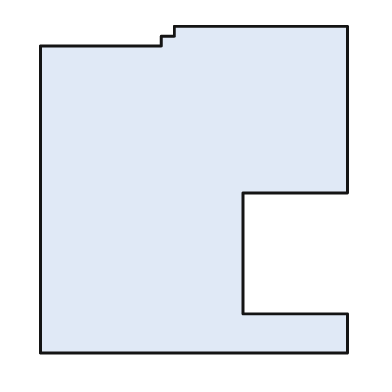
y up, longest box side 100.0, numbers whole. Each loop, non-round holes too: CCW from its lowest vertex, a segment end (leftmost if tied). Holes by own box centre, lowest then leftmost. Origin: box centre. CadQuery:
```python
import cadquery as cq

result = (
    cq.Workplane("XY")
    .moveTo(-47.0, -50.0)
    .lineTo(47.0, -50.0)
    .lineTo(47.0, -38.0)
    .lineTo(15.0, -38.0)
    .lineTo(15.0, -1.0)
    .lineTo(47.0, -1.0)
    .lineTo(47.0, 50.0)
    .lineTo(-6.0, 50.0)
    .lineTo(-6.0, 47.0)
    .lineTo(-10.0, 47.0)
    .lineTo(-10.0, 44.0)
    .lineTo(-47.0, 44.0)
    .close()
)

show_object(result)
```